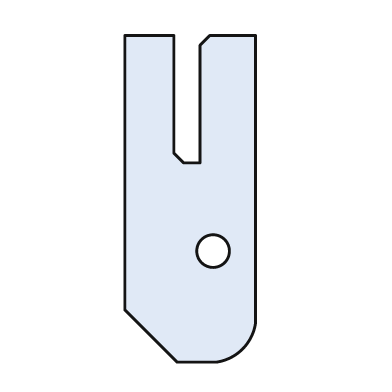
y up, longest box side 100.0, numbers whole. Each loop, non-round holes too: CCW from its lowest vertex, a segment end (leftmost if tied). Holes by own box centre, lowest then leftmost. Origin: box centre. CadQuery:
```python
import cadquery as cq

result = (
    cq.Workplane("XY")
    .moveTo(-4.0, -50.0)
    .lineTo(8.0, -50.0)
    .threePointArc((16.0, -46.0), (20.0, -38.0))
    .lineTo(20.0, 50.0)
    .lineTo(6.0, 50.0)
    .lineTo(3.0, 47.0)
    .lineTo(3.0, 11.0)
    .lineTo(-2.0, 11.0)
    .lineTo(-5.0, 14.0)
    .lineTo(-5.0, 50.0)
    .lineTo(-20.0, 50.0)
    .lineTo(-20.0, -34.0)
    .close()
    .moveTo(7.0, -16.0)
    .circle(5.0)
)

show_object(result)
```